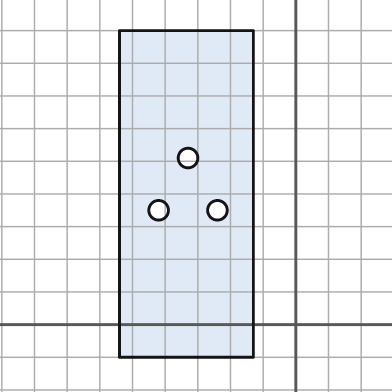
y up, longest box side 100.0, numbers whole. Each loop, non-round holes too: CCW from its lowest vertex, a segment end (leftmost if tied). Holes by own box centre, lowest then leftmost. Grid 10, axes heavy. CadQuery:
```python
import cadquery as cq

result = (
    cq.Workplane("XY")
    .moveTo(-54.0, -10.0)
    .lineTo(-13.0, -10.0)
    .lineTo(-13.0, 90.0)
    .lineTo(-54.0, 90.0)
    .close()
    .moveTo(-42.0, 35.0)
    .circle(3.0)
    .moveTo(-24.0, 35.0)
    .circle(3.0)
    .moveTo(-33.0, 51.0)
    .circle(3.0)
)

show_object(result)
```